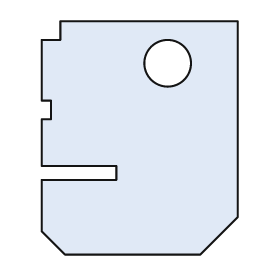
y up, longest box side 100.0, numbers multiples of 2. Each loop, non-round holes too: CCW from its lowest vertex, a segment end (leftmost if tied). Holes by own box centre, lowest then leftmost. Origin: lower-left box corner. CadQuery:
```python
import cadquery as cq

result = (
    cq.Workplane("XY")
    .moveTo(10.0, 0.0)
    .lineTo(68.0, 0.0)
    .lineTo(84.0, 16.0)
    .lineTo(84.0, 100.0)
    .lineTo(8.0, 100.0)
    .lineTo(8.0, 92.0)
    .lineTo(0.0, 92.0)
    .lineTo(0.0, 66.0)
    .lineTo(4.0, 66.0)
    .lineTo(4.0, 58.0)
    .lineTo(0.0, 58.0)
    .lineTo(0.0, 38.0)
    .lineTo(32.0, 38.0)
    .lineTo(32.0, 32.0)
    .lineTo(0.0, 32.0)
    .lineTo(0.0, 10.0)
    .close()
    .moveTo(54.0, 82.0)
    .circle(10.0)
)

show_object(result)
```